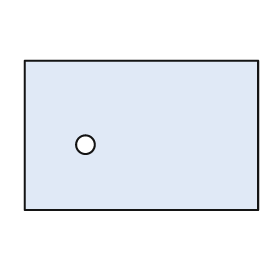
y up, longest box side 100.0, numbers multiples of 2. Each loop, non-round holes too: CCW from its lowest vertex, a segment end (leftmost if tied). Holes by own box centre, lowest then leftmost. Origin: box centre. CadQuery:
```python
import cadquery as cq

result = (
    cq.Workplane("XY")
    .moveTo(-50.0, -32.0)
    .lineTo(50.0, -32.0)
    .lineTo(50.0, 32.0)
    .lineTo(-50.0, 32.0)
    .close()
    .moveTo(-24.0, -4.0)
    .circle(4.0)
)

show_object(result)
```